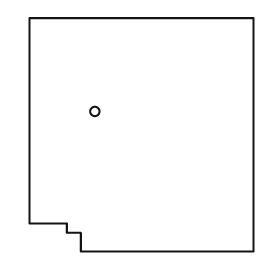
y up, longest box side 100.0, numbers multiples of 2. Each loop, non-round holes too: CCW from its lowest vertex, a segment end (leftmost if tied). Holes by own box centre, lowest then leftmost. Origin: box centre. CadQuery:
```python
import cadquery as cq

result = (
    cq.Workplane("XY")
    .moveTo(-26.0, -50.0)
    .lineTo(48.0, -50.0)
    .lineTo(48.0, 50.0)
    .lineTo(-48.0, 50.0)
    .lineTo(-48.0, -38.0)
    .lineTo(-32.0, -38.0)
    .lineTo(-32.0, -42.0)
    .lineTo(-26.0, -42.0)
    .close()
    .moveTo(-20.0, 10.0)
    .circle(2.0)
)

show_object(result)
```